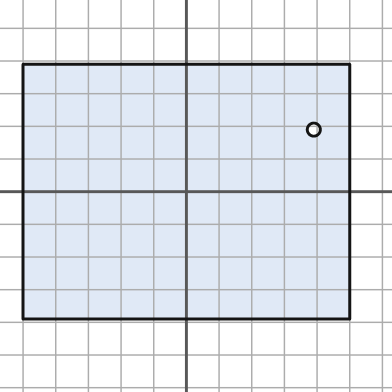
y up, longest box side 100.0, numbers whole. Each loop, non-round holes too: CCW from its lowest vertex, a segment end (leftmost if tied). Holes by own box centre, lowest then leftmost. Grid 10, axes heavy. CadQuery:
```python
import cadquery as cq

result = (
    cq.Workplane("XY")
    .moveTo(-50.0, -39.0)
    .lineTo(50.0, -39.0)
    .lineTo(50.0, 39.0)
    .lineTo(-50.0, 39.0)
    .close()
    .moveTo(39.0, 19.0)
    .circle(2.0)
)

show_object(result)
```